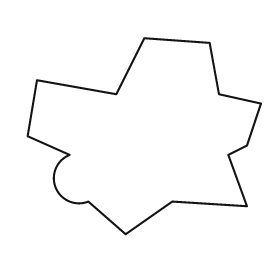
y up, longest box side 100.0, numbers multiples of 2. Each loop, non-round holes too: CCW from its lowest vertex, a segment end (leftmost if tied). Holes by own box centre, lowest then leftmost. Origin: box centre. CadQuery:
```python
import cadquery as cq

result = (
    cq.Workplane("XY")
    .moveTo(-8.0, -42.0)
    .lineTo(12.0, -28.0)
    .lineTo(44.0, -30.0)
    .lineTo(36.0, -8.0)
    .lineTo(44.0, -4.0)
    .lineTo(50.0, 14.0)
    .lineTo(32.0, 18.0)
    .lineTo(28.0, 40.0)
    .lineTo(0.0, 42.0)
    .lineTo(-12.0, 18.0)
    .lineTo(-46.0, 24.0)
    .lineTo(-50.0, 0.0)
    .lineTo(-32.0, -8.0)
    .threePointArc((-38.0, -22.0), (-24.0, -28.0))
    .close()
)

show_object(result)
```